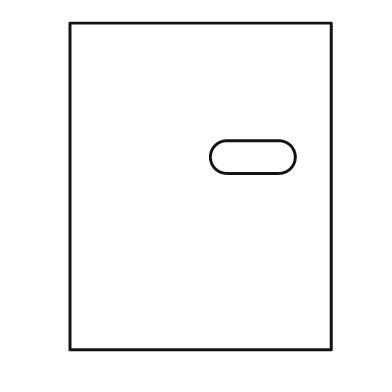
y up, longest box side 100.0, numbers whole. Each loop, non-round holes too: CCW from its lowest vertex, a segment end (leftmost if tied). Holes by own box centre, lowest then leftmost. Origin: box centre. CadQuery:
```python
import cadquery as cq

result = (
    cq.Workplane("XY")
    .moveTo(-40.0, -50.0)
    .lineTo(40.0, -50.0)
    .lineTo(40.0, 50.0)
    .lineTo(-40.0, 50.0)
    .close()
    .moveTo(8.0, 4.0)
    .lineTo(24.0, 4.0)
    .threePointArc((29.0, 9.0), (24.0, 14.0))
    .lineTo(8.0, 14.0)
    .threePointArc((3.0, 9.0), (8.0, 4.0))
    .close()
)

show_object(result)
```